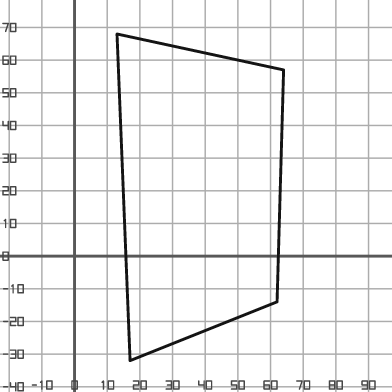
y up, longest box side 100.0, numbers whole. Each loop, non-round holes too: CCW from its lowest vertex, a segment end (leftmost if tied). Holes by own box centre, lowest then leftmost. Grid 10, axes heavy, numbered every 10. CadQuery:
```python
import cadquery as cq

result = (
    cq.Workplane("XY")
    .moveTo(17.0, -32.0)
    .lineTo(62.0, -14.0)
    .lineTo(64.0, 57.0)
    .lineTo(13.0, 68.0)
    .close()
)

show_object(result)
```